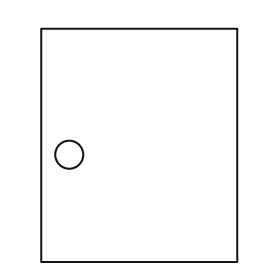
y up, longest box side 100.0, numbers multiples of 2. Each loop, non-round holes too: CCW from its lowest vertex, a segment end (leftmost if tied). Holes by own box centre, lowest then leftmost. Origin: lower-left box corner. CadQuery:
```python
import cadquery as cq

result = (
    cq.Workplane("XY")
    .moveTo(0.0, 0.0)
    .lineTo(84.0, 0.0)
    .lineTo(84.0, 100.0)
    .lineTo(0.0, 100.0)
    .close()
    .moveTo(12.0, 46.0)
    .circle(6.0)
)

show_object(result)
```